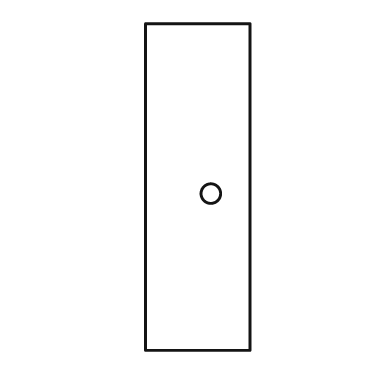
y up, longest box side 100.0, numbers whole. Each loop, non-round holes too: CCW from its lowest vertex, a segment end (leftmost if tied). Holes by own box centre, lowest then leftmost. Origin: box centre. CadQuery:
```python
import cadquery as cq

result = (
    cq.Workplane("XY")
    .moveTo(-16.0, -50.0)
    .lineTo(16.0, -50.0)
    .lineTo(16.0, 50.0)
    .lineTo(-16.0, 50.0)
    .close()
    .moveTo(4.0, -2.0)
    .circle(3.0)
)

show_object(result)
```